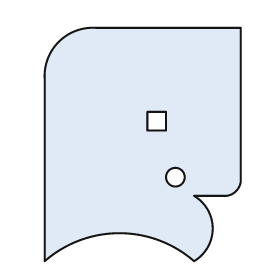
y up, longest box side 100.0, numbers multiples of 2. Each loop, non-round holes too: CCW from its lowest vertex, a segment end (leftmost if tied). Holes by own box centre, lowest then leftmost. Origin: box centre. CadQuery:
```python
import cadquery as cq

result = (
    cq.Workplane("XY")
    .moveTo(-42.0, -50.0)
    .threePointArc((-10.0, -38.0), (22.0, -50.0))
    .threePointArc((30.0, -36.0), (22.0, -22.0))
    .lineTo(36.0, -22.0)
    .threePointArc((40.0, -20.0), (42.0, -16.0))
    .lineTo(42.0, 50.0)
    .lineTo(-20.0, 50.0)
    .threePointArc((-36.0, 44.0), (-42.0, 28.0))
    .close()
    .moveTo(14.0, -14.0)
    .circle(4.0)
    .moveTo(2.0, 6.0)
    .lineTo(10.0, 6.0)
    .lineTo(10.0, 14.0)
    .lineTo(2.0, 14.0)
    .close()
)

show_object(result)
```